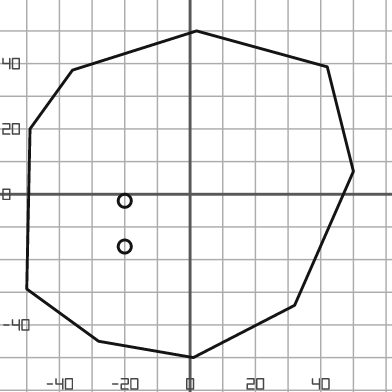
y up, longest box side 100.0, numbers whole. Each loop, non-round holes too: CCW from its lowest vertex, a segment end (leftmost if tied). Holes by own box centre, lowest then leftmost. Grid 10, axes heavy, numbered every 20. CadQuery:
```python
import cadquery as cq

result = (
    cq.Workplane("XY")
    .moveTo(1.0, -50.0)
    .lineTo(32.0, -34.0)
    .lineTo(50.0, 7.0)
    .lineTo(42.0, 39.0)
    .lineTo(2.0, 50.0)
    .lineTo(-36.0, 38.0)
    .lineTo(-49.0, 20.0)
    .lineTo(-50.0, -29.0)
    .lineTo(-28.0, -45.0)
    .close()
    .moveTo(-20.0, -16.0)
    .circle(2.0)
    .moveTo(-20.0, -2.0)
    .circle(2.0)
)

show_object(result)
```